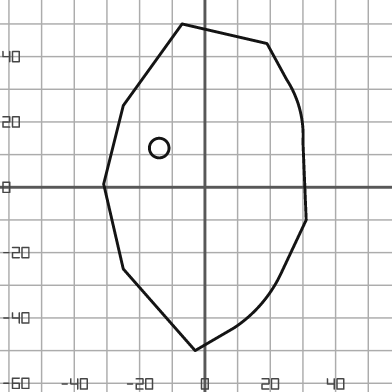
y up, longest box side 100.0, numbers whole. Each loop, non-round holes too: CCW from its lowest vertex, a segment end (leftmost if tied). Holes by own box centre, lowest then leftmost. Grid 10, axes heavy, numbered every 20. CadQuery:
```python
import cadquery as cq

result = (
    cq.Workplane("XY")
    .moveTo(-3.0, -50.0)
    .lineTo(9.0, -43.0)
    .threePointArc((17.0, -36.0), (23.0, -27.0))
    .lineTo(31.0, -10.0)
    .lineTo(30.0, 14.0)
    .threePointArc((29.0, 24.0), (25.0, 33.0))
    .lineTo(19.0, 44.0)
    .lineTo(-7.0, 50.0)
    .lineTo(-25.0, 25.0)
    .lineTo(-31.0, 1.0)
    .lineTo(-25.0, -25.0)
    .close()
    .moveTo(-14.0, 12.0)
    .circle(3.0)
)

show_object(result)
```